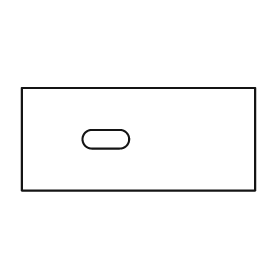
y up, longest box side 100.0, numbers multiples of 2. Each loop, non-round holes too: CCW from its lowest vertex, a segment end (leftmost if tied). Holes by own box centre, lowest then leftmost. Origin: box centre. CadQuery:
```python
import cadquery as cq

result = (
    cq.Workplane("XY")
    .moveTo(-50.0, -22.0)
    .lineTo(50.0, -22.0)
    .lineTo(50.0, 22.0)
    .lineTo(-50.0, 22.0)
    .close()
    .moveTo(-20.0, -4.0)
    .lineTo(-8.0, -4.0)
    .threePointArc((-4.0, 0.0), (-8.0, 4.0))
    .lineTo(-20.0, 4.0)
    .threePointArc((-24.0, 0.0), (-20.0, -4.0))
    .close()
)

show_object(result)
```